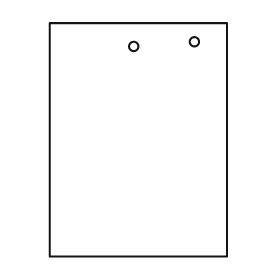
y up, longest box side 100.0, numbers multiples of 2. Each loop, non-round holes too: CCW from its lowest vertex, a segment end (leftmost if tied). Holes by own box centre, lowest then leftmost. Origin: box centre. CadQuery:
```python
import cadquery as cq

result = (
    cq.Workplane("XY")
    .moveTo(-38.0, -50.0)
    .lineTo(38.0, -50.0)
    .lineTo(38.0, 50.0)
    .lineTo(-38.0, 50.0)
    .close()
    .moveTo(-2.0, 40.0)
    .circle(2.0)
    .moveTo(24.0, 42.0)
    .circle(2.0)
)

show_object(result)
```